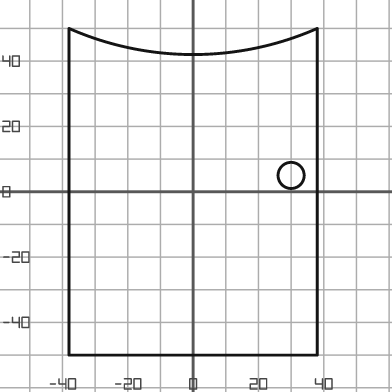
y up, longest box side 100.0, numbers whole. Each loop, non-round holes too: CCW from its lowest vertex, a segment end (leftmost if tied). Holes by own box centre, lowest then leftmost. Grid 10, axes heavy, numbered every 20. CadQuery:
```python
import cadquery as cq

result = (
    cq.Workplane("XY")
    .moveTo(-38.0, -50.0)
    .lineTo(38.0, -50.0)
    .lineTo(38.0, 50.0)
    .threePointArc((0.0, 42.0), (-38.0, 50.0))
    .close()
    .moveTo(30.0, 5.0)
    .circle(4.0)
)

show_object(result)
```